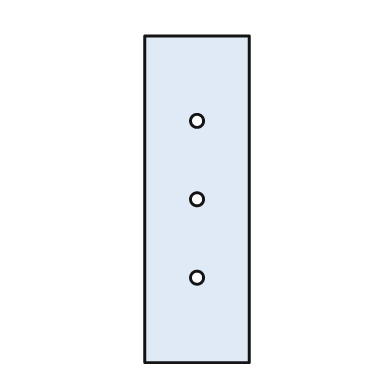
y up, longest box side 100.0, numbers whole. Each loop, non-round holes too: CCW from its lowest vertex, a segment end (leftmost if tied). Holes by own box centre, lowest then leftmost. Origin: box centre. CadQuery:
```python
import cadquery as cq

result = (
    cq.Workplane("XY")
    .moveTo(-16.0, -50.0)
    .lineTo(16.0, -50.0)
    .lineTo(16.0, 50.0)
    .lineTo(-16.0, 50.0)
    .close()
    .moveTo(0.0, -24.0)
    .circle(2.0)
    .moveTo(0.0, 0.0)
    .circle(2.0)
    .moveTo(0.0, 24.0)
    .circle(2.0)
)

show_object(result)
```